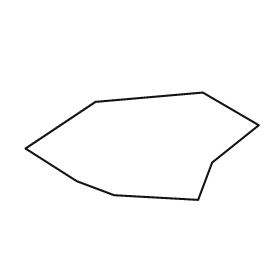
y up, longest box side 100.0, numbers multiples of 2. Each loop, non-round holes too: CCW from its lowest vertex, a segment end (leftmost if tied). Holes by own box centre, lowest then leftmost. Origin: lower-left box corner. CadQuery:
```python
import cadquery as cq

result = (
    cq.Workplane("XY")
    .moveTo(74.0, 0.0)
    .lineTo(80.0, 16.0)
    .lineTo(100.0, 32.0)
    .lineTo(76.0, 46.0)
    .lineTo(30.0, 42.0)
    .lineTo(0.0, 22.0)
    .lineTo(22.0, 8.0)
    .lineTo(38.0, 2.0)
    .close()
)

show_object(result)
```